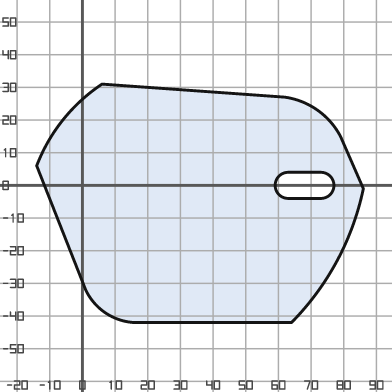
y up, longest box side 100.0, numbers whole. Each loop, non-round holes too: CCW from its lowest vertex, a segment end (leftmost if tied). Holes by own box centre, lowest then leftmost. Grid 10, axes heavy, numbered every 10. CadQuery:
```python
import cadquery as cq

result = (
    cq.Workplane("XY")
    .moveTo(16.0, -42.0)
    .lineTo(64.0, -42.0)
    .threePointArc((78.0, -23.0), (86.0, -1.0))
    .lineTo(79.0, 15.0)
    .threePointArc((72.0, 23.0), (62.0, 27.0))
    .lineTo(6.0, 31.0)
    .threePointArc((-6.0, 20.0), (-14.0, 6.0))
    .lineTo(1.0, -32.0)
    .threePointArc((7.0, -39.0), (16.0, -42.0))
    .close()
    .moveTo(63.0, -4.0)
    .lineTo(73.0, -4.0)
    .threePointArc((77.0, 0.0), (73.0, 4.0))
    .lineTo(63.0, 4.0)
    .threePointArc((59.0, 0.0), (63.0, -4.0))
    .close()
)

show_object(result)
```